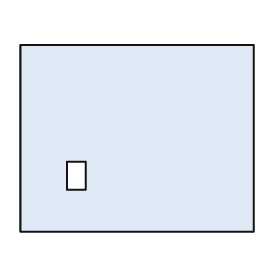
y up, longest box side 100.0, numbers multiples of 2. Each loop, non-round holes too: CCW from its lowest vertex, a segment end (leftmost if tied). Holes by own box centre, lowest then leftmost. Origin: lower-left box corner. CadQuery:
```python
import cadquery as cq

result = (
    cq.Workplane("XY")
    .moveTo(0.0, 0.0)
    .lineTo(100.0, 0.0)
    .lineTo(100.0, 80.0)
    .lineTo(0.0, 80.0)
    .close()
    .moveTo(20.0, 18.0)
    .lineTo(28.0, 18.0)
    .lineTo(28.0, 30.0)
    .lineTo(20.0, 30.0)
    .close()
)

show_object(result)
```